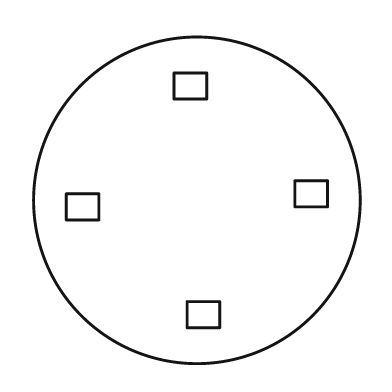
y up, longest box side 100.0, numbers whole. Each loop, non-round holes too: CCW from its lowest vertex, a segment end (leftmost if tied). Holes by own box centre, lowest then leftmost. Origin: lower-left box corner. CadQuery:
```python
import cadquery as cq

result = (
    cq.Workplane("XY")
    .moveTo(50.0, 50.0)
    .circle(50.0)
    .moveTo(47.0, 11.0)
    .lineTo(57.0, 11.0)
    .lineTo(57.0, 19.0)
    .lineTo(47.0, 19.0)
    .close()
    .moveTo(10.0, 44.0)
    .lineTo(20.0, 44.0)
    .lineTo(20.0, 52.0)
    .lineTo(10.0, 52.0)
    .close()
    .moveTo(80.0, 48.0)
    .lineTo(90.0, 48.0)
    .lineTo(90.0, 56.0)
    .lineTo(80.0, 56.0)
    .close()
    .moveTo(43.0, 81.0)
    .lineTo(53.0, 81.0)
    .lineTo(53.0, 89.0)
    .lineTo(43.0, 89.0)
    .close()
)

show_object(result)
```